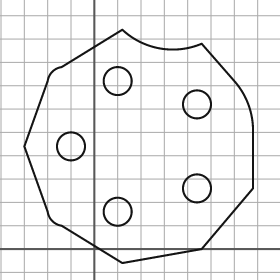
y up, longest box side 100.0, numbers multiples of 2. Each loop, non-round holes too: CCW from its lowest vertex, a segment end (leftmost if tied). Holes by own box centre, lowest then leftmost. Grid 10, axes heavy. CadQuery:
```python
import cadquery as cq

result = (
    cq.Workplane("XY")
    .moveTo(12.0, -6.0)
    .lineTo(46.0, 0.0)
    .lineTo(68.0, 26.0)
    .lineTo(68.0, 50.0)
    .threePointArc((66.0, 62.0), (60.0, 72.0))
    .lineTo(46.0, 88.0)
    .threePointArc((28.0, 86.0), (12.0, 94.0))
    .lineTo(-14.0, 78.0)
    .threePointArc((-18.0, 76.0), (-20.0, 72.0))
    .lineTo(-30.0, 44.0)
    .lineTo(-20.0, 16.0)
    .threePointArc((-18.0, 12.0), (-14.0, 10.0))
    .close()
    .moveTo(10.0, 16.0)
    .circle(6.0)
    .moveTo(44.0, 26.0)
    .circle(6.0)
    .moveTo(-10.0, 44.0)
    .circle(6.0)
    .moveTo(44.0, 62.0)
    .circle(6.0)
    .moveTo(10.0, 72.0)
    .circle(6.0)
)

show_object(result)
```